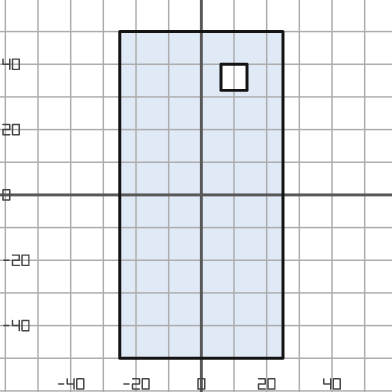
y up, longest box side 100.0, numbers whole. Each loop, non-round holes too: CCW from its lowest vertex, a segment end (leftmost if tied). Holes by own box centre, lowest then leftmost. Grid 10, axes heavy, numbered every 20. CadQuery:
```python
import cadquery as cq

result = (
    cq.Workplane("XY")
    .moveTo(-25.0, -50.0)
    .lineTo(25.0, -50.0)
    .lineTo(25.0, 50.0)
    .lineTo(-25.0, 50.0)
    .close()
    .moveTo(6.0, 32.0)
    .lineTo(14.0, 32.0)
    .lineTo(14.0, 40.0)
    .lineTo(6.0, 40.0)
    .close()
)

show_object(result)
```